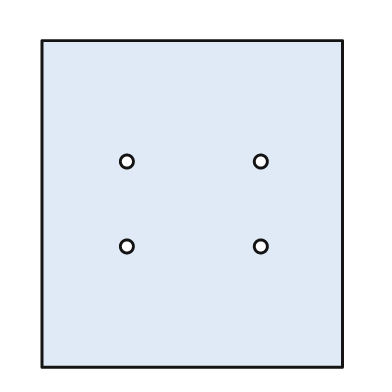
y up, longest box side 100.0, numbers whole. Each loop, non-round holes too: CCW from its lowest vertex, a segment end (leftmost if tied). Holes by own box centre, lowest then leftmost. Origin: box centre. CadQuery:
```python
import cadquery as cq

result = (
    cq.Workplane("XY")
    .moveTo(-46.0, -50.0)
    .lineTo(46.0, -50.0)
    .lineTo(46.0, 50.0)
    .lineTo(-46.0, 50.0)
    .close()
    .moveTo(-20.0, -13.0)
    .circle(2.0)
    .moveTo(21.0, -13.0)
    .circle(2.0)
    .moveTo(-20.0, 13.0)
    .circle(2.0)
    .moveTo(21.0, 13.0)
    .circle(2.0)
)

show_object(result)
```